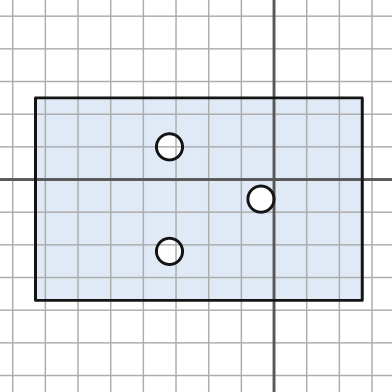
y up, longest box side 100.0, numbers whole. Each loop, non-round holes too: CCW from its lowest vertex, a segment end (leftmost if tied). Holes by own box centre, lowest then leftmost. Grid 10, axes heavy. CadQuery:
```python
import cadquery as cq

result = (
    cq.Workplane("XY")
    .moveTo(-73.0, -37.0)
    .lineTo(27.0, -37.0)
    .lineTo(27.0, 25.0)
    .lineTo(-73.0, 25.0)
    .close()
    .moveTo(-32.0, -22.0)
    .circle(4.0)
    .moveTo(-4.0, -6.0)
    .circle(4.0)
    .moveTo(-32.0, 10.0)
    .circle(4.0)
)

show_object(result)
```